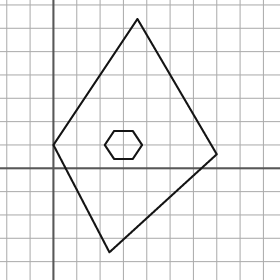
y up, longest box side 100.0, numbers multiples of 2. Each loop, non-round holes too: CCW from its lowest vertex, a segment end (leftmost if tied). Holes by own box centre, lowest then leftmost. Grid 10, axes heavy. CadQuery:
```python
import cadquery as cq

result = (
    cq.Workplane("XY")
    .moveTo(24.0, -36.0)
    .lineTo(70.0, 6.0)
    .lineTo(36.0, 64.0)
    .lineTo(0.0, 10.0)
    .close()
    .moveTo(26.0, 4.0)
    .lineTo(34.0, 4.0)
    .lineTo(38.0, 10.0)
    .lineTo(34.0, 16.0)
    .lineTo(26.0, 16.0)
    .lineTo(22.0, 10.0)
    .close()
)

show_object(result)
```